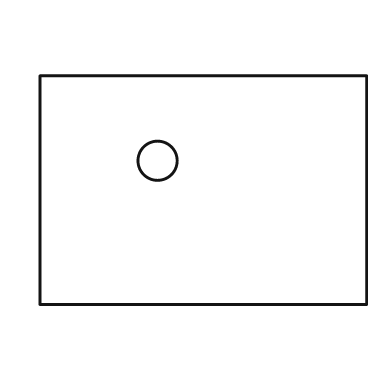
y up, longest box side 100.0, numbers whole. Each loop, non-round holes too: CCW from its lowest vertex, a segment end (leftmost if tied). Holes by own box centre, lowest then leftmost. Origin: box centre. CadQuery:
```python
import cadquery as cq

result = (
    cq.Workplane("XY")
    .moveTo(-50.0, -35.0)
    .lineTo(50.0, -35.0)
    .lineTo(50.0, 35.0)
    .lineTo(-50.0, 35.0)
    .close()
    .moveTo(-14.0, 9.0)
    .circle(6.0)
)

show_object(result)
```